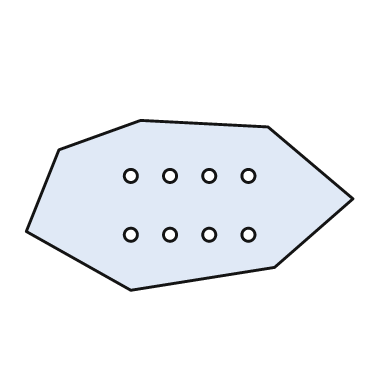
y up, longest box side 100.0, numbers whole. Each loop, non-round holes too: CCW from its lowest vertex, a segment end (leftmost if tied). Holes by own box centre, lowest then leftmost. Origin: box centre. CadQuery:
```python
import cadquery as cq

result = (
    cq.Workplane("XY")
    .moveTo(-18.0, -26.0)
    .lineTo(26.0, -19.0)
    .lineTo(50.0, 2.0)
    .lineTo(24.0, 24.0)
    .lineTo(-15.0, 26.0)
    .lineTo(-40.0, 17.0)
    .lineTo(-50.0, -8.0)
    .close()
    .moveTo(-18.0, -9.0)
    .circle(2.0)
    .moveTo(-6.0, -9.0)
    .circle(2.0)
    .moveTo(6.0, -9.0)
    .circle(2.0)
    .moveTo(18.0, -9.0)
    .circle(2.0)
    .moveTo(-18.0, 9.0)
    .circle(2.0)
    .moveTo(-6.0, 9.0)
    .circle(2.0)
    .moveTo(6.0, 9.0)
    .circle(2.0)
    .moveTo(18.0, 9.0)
    .circle(2.0)
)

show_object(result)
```